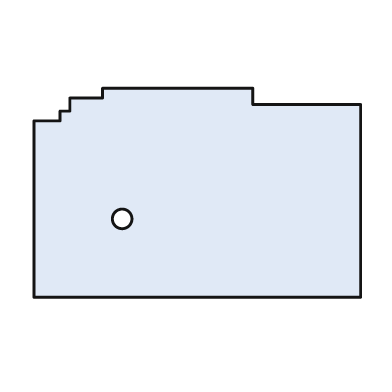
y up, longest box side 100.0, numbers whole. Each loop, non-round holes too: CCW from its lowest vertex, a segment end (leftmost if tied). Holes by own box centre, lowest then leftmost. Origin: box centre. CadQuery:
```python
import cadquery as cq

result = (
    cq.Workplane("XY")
    .moveTo(-50.0, -32.0)
    .lineTo(50.0, -32.0)
    .lineTo(50.0, 27.0)
    .lineTo(17.0, 27.0)
    .lineTo(17.0, 32.0)
    .lineTo(-29.0, 32.0)
    .lineTo(-29.0, 29.0)
    .lineTo(-39.0, 29.0)
    .lineTo(-39.0, 25.0)
    .lineTo(-42.0, 25.0)
    .lineTo(-42.0, 22.0)
    .lineTo(-50.0, 22.0)
    .close()
    .moveTo(-23.0, -8.0)
    .circle(3.0)
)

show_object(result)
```